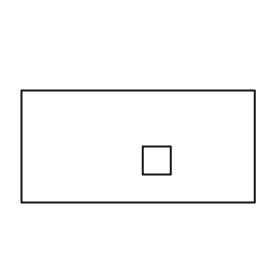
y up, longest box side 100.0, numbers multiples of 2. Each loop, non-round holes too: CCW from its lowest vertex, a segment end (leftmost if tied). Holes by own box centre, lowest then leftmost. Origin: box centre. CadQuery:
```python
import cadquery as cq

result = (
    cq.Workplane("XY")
    .moveTo(-50.0, -24.0)
    .lineTo(50.0, -24.0)
    .lineTo(50.0, 24.0)
    .lineTo(-50.0, 24.0)
    .close()
    .moveTo(2.0, -12.0)
    .lineTo(14.0, -12.0)
    .lineTo(14.0, 0.0)
    .lineTo(2.0, 0.0)
    .close()
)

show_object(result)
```